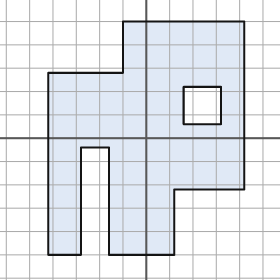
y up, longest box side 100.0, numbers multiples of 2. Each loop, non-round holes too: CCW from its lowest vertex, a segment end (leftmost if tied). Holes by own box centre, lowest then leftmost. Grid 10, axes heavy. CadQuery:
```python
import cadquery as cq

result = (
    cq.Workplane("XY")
    .moveTo(-42.0, -50.0)
    .lineTo(-28.0, -50.0)
    .lineTo(-28.0, -4.0)
    .lineTo(-16.0, -4.0)
    .lineTo(-16.0, -50.0)
    .lineTo(12.0, -50.0)
    .lineTo(12.0, -22.0)
    .lineTo(42.0, -22.0)
    .lineTo(42.0, 50.0)
    .lineTo(-10.0, 50.0)
    .lineTo(-10.0, 28.0)
    .lineTo(-42.0, 28.0)
    .close()
    .moveTo(16.0, 6.0)
    .lineTo(32.0, 6.0)
    .lineTo(32.0, 22.0)
    .lineTo(16.0, 22.0)
    .close()
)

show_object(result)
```